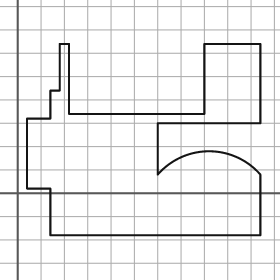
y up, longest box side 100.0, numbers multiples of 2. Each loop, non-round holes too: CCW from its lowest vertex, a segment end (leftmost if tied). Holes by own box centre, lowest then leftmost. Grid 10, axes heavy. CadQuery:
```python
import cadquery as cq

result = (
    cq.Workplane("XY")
    .moveTo(14.0, -18.0)
    .lineTo(104.0, -18.0)
    .lineTo(104.0, 8.0)
    .threePointArc((82.0, 18.0), (60.0, 8.0))
    .lineTo(60.0, 30.0)
    .lineTo(104.0, 30.0)
    .lineTo(104.0, 64.0)
    .lineTo(80.0, 64.0)
    .lineTo(80.0, 34.0)
    .lineTo(22.0, 34.0)
    .lineTo(22.0, 64.0)
    .lineTo(18.0, 64.0)
    .lineTo(18.0, 44.0)
    .lineTo(14.0, 44.0)
    .lineTo(14.0, 32.0)
    .lineTo(4.0, 32.0)
    .lineTo(4.0, 2.0)
    .lineTo(14.0, 2.0)
    .close()
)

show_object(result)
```